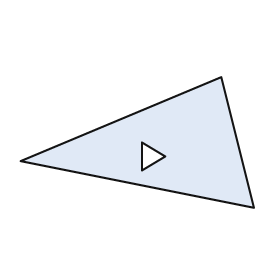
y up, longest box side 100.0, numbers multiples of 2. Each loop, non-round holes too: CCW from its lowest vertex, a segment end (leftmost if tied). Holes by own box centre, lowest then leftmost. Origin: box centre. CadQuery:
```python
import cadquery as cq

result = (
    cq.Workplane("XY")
    .moveTo(50.0, -28.0)
    .lineTo(36.0, 28.0)
    .lineTo(-50.0, -8.0)
    .close()
    .moveTo(2.0, -12.0)
    .lineTo(12.0, -6.0)
    .lineTo(2.0, 0.0)
    .close()
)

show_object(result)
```